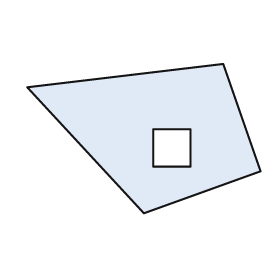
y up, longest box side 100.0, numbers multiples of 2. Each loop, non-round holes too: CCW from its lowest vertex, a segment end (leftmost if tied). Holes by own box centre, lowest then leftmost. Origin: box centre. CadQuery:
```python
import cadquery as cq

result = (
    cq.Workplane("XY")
    .moveTo(0.0, -32.0)
    .lineTo(50.0, -14.0)
    .lineTo(34.0, 32.0)
    .lineTo(-50.0, 22.0)
    .close()
    .moveTo(4.0, -12.0)
    .lineTo(20.0, -12.0)
    .lineTo(20.0, 4.0)
    .lineTo(4.0, 4.0)
    .close()
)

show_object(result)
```